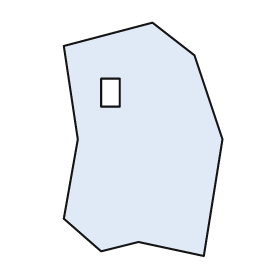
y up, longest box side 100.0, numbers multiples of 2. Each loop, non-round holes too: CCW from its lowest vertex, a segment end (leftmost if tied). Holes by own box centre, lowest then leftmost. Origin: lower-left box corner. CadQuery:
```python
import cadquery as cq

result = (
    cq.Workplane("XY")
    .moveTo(60.0, 0.0)
    .lineTo(68.0, 50.0)
    .lineTo(56.0, 86.0)
    .lineTo(38.0, 100.0)
    .lineTo(0.0, 90.0)
    .lineTo(6.0, 50.0)
    .lineTo(0.0, 16.0)
    .lineTo(16.0, 2.0)
    .lineTo(32.0, 6.0)
    .close()
    .moveTo(16.0, 64.0)
    .lineTo(24.0, 64.0)
    .lineTo(24.0, 76.0)
    .lineTo(16.0, 76.0)
    .close()
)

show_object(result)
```